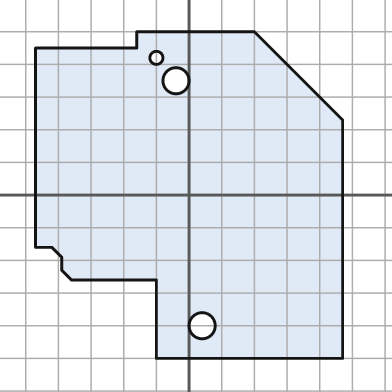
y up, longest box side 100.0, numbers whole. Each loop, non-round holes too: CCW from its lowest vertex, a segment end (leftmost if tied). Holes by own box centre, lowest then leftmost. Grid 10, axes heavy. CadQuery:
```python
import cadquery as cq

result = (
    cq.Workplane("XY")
    .moveTo(-10.0, -50.0)
    .lineTo(47.0, -50.0)
    .lineTo(47.0, 23.0)
    .lineTo(20.0, 50.0)
    .lineTo(-16.0, 50.0)
    .lineTo(-16.0, 45.0)
    .lineTo(-47.0, 45.0)
    .lineTo(-47.0, -16.0)
    .lineTo(-42.0, -16.0)
    .lineTo(-39.0, -19.0)
    .lineTo(-39.0, -23.0)
    .lineTo(-36.0, -26.0)
    .lineTo(-10.0, -26.0)
    .close()
    .moveTo(4.0, -40.0)
    .circle(4.0)
    .moveTo(-4.0, 35.0)
    .circle(4.0)
    .moveTo(-10.0, 42.0)
    .circle(2.0)
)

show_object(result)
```